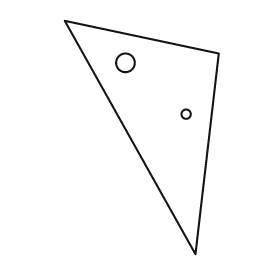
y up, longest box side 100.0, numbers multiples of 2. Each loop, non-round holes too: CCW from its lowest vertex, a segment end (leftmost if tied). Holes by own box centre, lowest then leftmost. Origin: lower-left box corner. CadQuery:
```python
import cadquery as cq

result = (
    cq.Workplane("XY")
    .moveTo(56.0, 0.0)
    .lineTo(66.0, 86.0)
    .lineTo(0.0, 100.0)
    .close()
    .moveTo(52.0, 60.0)
    .circle(2.0)
    .moveTo(26.0, 82.0)
    .circle(4.0)
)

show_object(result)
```